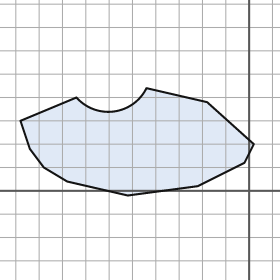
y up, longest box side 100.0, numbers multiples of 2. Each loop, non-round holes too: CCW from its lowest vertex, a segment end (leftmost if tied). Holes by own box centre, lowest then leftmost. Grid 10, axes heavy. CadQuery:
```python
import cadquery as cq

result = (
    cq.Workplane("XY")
    .moveTo(-52.0, -2.0)
    .lineTo(-22.0, 2.0)
    .lineTo(-2.0, 12.0)
    .lineTo(2.0, 20.0)
    .lineTo(-18.0, 38.0)
    .lineTo(-44.0, 44.0)
    .threePointArc((-58.0, 34.0), (-74.0, 40.0))
    .lineTo(-98.0, 30.0)
    .lineTo(-94.0, 18.0)
    .lineTo(-88.0, 10.0)
    .lineTo(-78.0, 4.0)
    .close()
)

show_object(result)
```